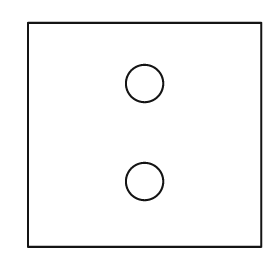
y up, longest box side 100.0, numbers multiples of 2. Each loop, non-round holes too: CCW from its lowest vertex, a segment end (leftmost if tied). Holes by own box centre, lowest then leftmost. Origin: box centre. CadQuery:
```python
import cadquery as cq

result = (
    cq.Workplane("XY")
    .moveTo(-50.0, -48.0)
    .lineTo(50.0, -48.0)
    .lineTo(50.0, 48.0)
    .lineTo(-50.0, 48.0)
    .close()
    .moveTo(0.0, -20.0)
    .circle(8.0)
    .moveTo(0.0, 22.0)
    .circle(8.0)
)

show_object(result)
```